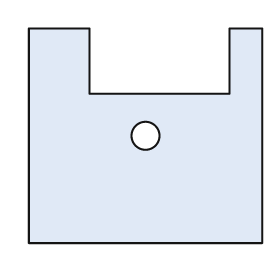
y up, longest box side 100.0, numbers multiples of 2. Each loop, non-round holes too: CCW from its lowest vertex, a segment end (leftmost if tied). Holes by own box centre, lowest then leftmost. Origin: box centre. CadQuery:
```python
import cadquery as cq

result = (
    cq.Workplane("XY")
    .moveTo(-50.0, -46.0)
    .lineTo(50.0, -46.0)
    .lineTo(50.0, 46.0)
    .lineTo(36.0, 46.0)
    .lineTo(36.0, 18.0)
    .lineTo(-24.0, 18.0)
    .lineTo(-24.0, 46.0)
    .lineTo(-50.0, 46.0)
    .close()
    .moveTo(0.0, 0.0)
    .circle(6.0)
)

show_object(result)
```